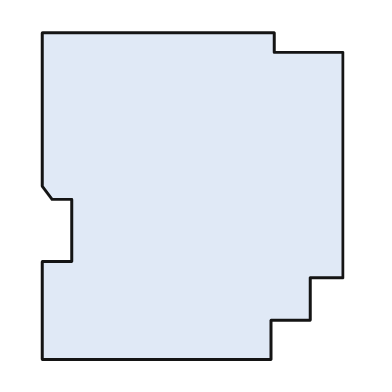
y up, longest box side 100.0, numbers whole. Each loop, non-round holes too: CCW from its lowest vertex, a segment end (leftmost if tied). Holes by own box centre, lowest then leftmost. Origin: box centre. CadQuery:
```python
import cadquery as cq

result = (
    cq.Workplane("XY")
    .moveTo(-46.0, -50.0)
    .lineTo(24.0, -50.0)
    .lineTo(24.0, -38.0)
    .lineTo(36.0, -38.0)
    .lineTo(36.0, -25.0)
    .lineTo(46.0, -25.0)
    .lineTo(46.0, 44.0)
    .lineTo(25.0, 44.0)
    .lineTo(25.0, 50.0)
    .lineTo(-46.0, 50.0)
    .lineTo(-46.0, 3.0)
    .lineTo(-43.0, -1.0)
    .lineTo(-37.0, -1.0)
    .lineTo(-37.0, -20.0)
    .lineTo(-46.0, -20.0)
    .close()
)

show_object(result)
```